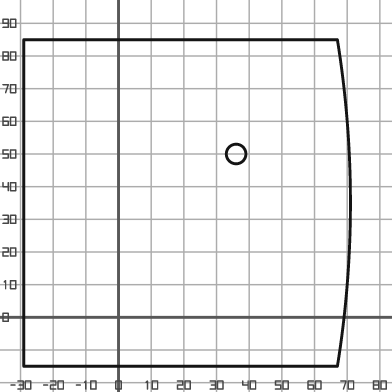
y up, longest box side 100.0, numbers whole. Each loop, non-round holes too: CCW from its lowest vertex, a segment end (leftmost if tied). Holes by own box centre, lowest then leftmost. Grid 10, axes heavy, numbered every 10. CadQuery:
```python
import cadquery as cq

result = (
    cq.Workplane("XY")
    .moveTo(-29.0, -15.0)
    .lineTo(67.0, -15.0)
    .threePointArc((71.0, 35.0), (67.0, 85.0))
    .lineTo(-29.0, 85.0)
    .close()
    .moveTo(36.0, 50.0)
    .circle(3.0)
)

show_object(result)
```